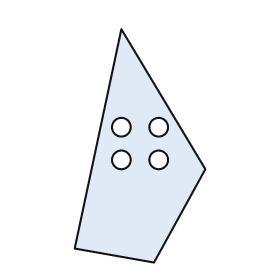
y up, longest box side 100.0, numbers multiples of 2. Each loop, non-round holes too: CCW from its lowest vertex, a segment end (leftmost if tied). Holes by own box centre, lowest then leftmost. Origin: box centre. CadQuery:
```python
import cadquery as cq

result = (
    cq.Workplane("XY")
    .moveTo(6.0, -50.0)
    .lineTo(28.0, -10.0)
    .lineTo(-8.0, 50.0)
    .lineTo(-28.0, -44.0)
    .close()
    .moveTo(-8.0, -6.0)
    .circle(4.0)
    .moveTo(8.0, -6.0)
    .circle(4.0)
    .moveTo(-8.0, 8.0)
    .circle(4.0)
    .moveTo(8.0, 8.0)
    .circle(4.0)
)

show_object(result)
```